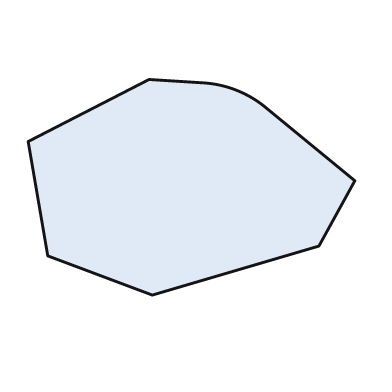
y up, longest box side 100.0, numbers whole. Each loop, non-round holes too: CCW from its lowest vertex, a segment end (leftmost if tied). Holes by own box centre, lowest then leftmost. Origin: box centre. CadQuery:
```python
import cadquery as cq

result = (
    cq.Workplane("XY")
    .moveTo(-12.0, -33.0)
    .lineTo(39.0, -18.0)
    .lineTo(50.0, 2.0)
    .lineTo(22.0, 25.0)
    .threePointArc((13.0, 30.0), (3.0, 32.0))
    .lineTo(-13.0, 33.0)
    .lineTo(-50.0, 14.0)
    .lineTo(-44.0, -21.0)
    .close()
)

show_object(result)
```